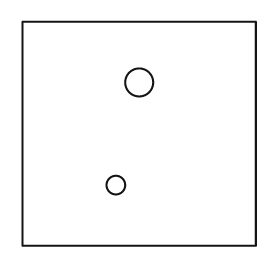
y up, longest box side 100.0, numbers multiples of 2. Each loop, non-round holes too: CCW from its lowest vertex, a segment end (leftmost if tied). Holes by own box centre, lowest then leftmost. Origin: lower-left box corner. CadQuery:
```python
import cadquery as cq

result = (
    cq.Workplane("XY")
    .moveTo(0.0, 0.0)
    .lineTo(100.0, 0.0)
    .lineTo(100.0, 96.0)
    .lineTo(0.0, 96.0)
    .close()
    .moveTo(40.0, 26.0)
    .circle(4.0)
    .moveTo(50.0, 70.0)
    .circle(6.0)
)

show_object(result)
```